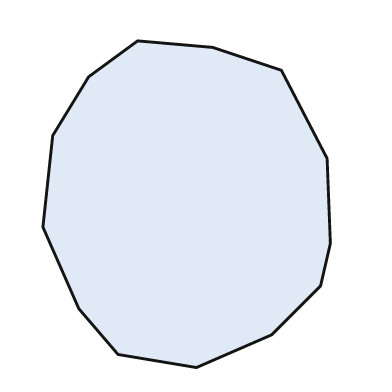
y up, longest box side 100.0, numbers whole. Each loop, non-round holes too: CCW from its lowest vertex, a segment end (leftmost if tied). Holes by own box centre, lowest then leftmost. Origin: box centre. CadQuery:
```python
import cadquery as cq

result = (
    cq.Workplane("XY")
    .moveTo(3.0, -50.0)
    .lineTo(26.0, -40.0)
    .lineTo(41.0, -25.0)
    .lineTo(44.0, -12.0)
    .lineTo(43.0, 14.0)
    .lineTo(29.0, 41.0)
    .lineTo(8.0, 48.0)
    .lineTo(-15.0, 50.0)
    .lineTo(-30.0, 39.0)
    .lineTo(-41.0, 21.0)
    .lineTo(-44.0, -7.0)
    .lineTo(-33.0, -32.0)
    .lineTo(-21.0, -46.0)
    .close()
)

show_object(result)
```